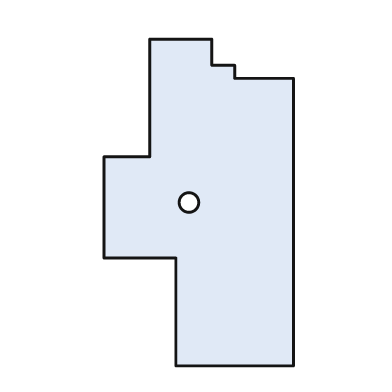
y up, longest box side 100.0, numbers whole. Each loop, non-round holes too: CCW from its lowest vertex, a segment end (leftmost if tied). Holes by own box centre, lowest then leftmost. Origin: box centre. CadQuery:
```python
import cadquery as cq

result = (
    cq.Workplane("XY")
    .moveTo(-7.0, -50.0)
    .lineTo(29.0, -50.0)
    .lineTo(29.0, 38.0)
    .lineTo(11.0, 38.0)
    .lineTo(11.0, 42.0)
    .lineTo(4.0, 42.0)
    .lineTo(4.0, 50.0)
    .lineTo(-15.0, 50.0)
    .lineTo(-15.0, 14.0)
    .lineTo(-29.0, 14.0)
    .lineTo(-29.0, -17.0)
    .lineTo(-7.0, -17.0)
    .close()
    .moveTo(-3.0, 0.0)
    .circle(3.0)
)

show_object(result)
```